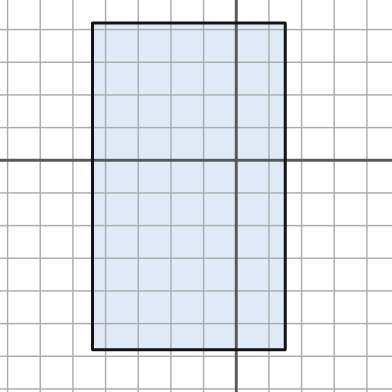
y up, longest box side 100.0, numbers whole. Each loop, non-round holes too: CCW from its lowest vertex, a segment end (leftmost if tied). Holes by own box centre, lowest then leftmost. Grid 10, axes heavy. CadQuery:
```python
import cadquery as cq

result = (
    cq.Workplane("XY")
    .moveTo(-44.0, -58.0)
    .lineTo(15.0, -58.0)
    .lineTo(15.0, 42.0)
    .lineTo(-44.0, 42.0)
    .close()
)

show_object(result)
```